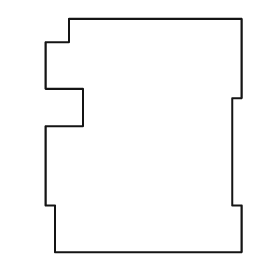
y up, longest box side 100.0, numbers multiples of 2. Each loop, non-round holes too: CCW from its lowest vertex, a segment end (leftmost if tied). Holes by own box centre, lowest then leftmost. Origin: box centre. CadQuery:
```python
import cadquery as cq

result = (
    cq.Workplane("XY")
    .moveTo(-38.0, -50.0)
    .lineTo(42.0, -50.0)
    .lineTo(42.0, -30.0)
    .lineTo(38.0, -30.0)
    .lineTo(38.0, 16.0)
    .lineTo(42.0, 16.0)
    .lineTo(42.0, 50.0)
    .lineTo(-32.0, 50.0)
    .lineTo(-32.0, 40.0)
    .lineTo(-42.0, 40.0)
    .lineTo(-42.0, 20.0)
    .lineTo(-26.0, 20.0)
    .lineTo(-26.0, 4.0)
    .lineTo(-42.0, 4.0)
    .lineTo(-42.0, -30.0)
    .lineTo(-38.0, -30.0)
    .close()
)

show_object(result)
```